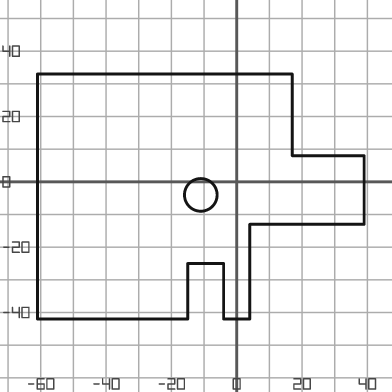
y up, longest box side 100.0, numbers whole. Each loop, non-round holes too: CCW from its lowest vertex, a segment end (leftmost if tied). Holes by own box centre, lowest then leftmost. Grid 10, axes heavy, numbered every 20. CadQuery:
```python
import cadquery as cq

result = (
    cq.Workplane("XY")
    .moveTo(-61.0, -42.0)
    .lineTo(-15.0, -42.0)
    .lineTo(-15.0, -25.0)
    .lineTo(-4.0, -25.0)
    .lineTo(-4.0, -42.0)
    .lineTo(4.0, -42.0)
    .lineTo(4.0, -13.0)
    .lineTo(39.0, -13.0)
    .lineTo(39.0, 8.0)
    .lineTo(17.0, 8.0)
    .lineTo(17.0, 33.0)
    .lineTo(-61.0, 33.0)
    .close()
    .moveTo(-11.0, -4.0)
    .circle(5.0)
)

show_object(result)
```